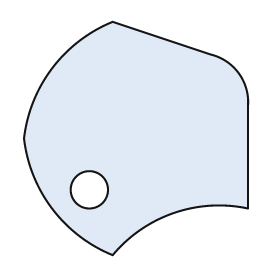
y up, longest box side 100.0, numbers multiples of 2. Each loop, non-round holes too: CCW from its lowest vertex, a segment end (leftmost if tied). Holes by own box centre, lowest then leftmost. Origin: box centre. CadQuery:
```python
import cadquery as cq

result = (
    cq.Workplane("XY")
    .moveTo(-10.0, -50.0)
    .threePointArc((16.0, -32.0), (48.0, -30.0))
    .lineTo(48.0, 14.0)
    .threePointArc((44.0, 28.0), (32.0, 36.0))
    .lineTo(-10.0, 50.0)
    .threePointArc((-36.0, 30.0), (-48.0, 0.0))
    .threePointArc((-36.0, -30.0), (-10.0, -50.0))
    .close()
    .moveTo(-20.0, -22.0)
    .circle(8.0)
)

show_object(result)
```